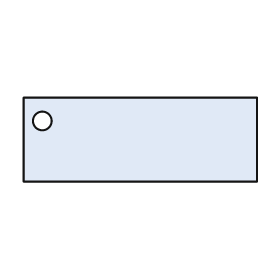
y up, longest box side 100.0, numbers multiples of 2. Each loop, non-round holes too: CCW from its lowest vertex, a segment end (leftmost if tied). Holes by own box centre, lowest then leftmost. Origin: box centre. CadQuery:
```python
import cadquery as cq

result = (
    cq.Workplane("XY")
    .moveTo(-50.0, -18.0)
    .lineTo(50.0, -18.0)
    .lineTo(50.0, 18.0)
    .lineTo(-50.0, 18.0)
    .close()
    .moveTo(-42.0, 8.0)
    .circle(4.0)
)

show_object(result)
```